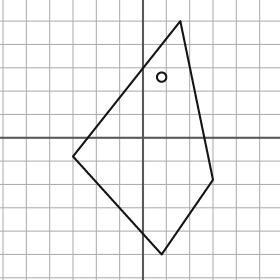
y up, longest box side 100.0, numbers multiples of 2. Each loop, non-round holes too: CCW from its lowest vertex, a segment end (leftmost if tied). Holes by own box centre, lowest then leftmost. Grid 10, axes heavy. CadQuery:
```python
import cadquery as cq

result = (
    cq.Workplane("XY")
    .moveTo(8.0, -50.0)
    .lineTo(30.0, -18.0)
    .lineTo(16.0, 50.0)
    .lineTo(-30.0, -8.0)
    .close()
    .moveTo(8.0, 26.0)
    .circle(2.0)
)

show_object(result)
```